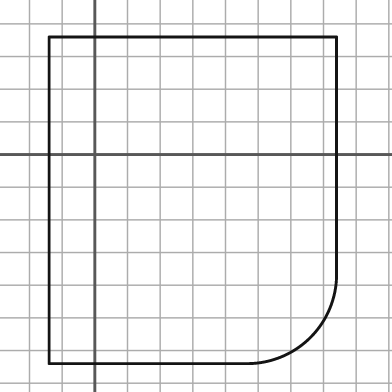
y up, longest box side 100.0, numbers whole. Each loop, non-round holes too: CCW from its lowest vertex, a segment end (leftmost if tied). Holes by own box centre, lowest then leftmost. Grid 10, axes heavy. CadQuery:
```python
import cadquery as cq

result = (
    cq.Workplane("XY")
    .moveTo(-14.0, -64.0)
    .lineTo(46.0, -64.0)
    .threePointArc((66.0, -56.0), (74.0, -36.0))
    .lineTo(74.0, 36.0)
    .lineTo(-14.0, 36.0)
    .close()
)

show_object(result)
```